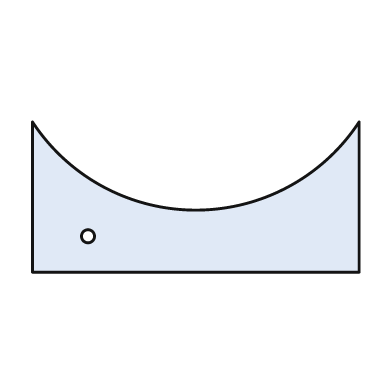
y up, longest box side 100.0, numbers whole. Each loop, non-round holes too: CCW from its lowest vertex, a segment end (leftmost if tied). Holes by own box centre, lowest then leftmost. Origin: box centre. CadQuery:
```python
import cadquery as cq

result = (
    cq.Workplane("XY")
    .moveTo(-50.0, -23.0)
    .lineTo(50.0, -23.0)
    .lineTo(50.0, 23.0)
    .threePointArc((0.0, -4.0), (-50.0, 23.0))
    .close()
    .moveTo(-33.0, -12.0)
    .circle(2.0)
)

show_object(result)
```